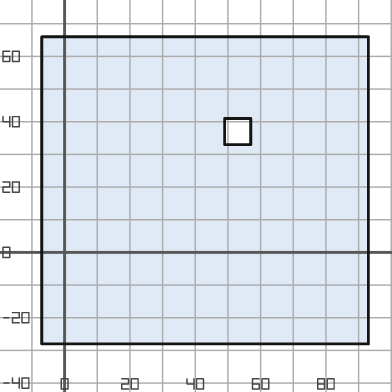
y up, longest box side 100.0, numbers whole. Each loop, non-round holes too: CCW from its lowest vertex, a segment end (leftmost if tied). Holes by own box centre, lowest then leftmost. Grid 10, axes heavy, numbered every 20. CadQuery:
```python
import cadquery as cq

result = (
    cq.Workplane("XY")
    .moveTo(-7.0, -28.0)
    .lineTo(93.0, -28.0)
    .lineTo(93.0, 66.0)
    .lineTo(-7.0, 66.0)
    .close()
    .moveTo(49.0, 33.0)
    .lineTo(57.0, 33.0)
    .lineTo(57.0, 41.0)
    .lineTo(49.0, 41.0)
    .close()
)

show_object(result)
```